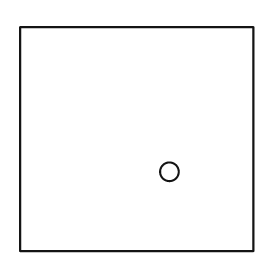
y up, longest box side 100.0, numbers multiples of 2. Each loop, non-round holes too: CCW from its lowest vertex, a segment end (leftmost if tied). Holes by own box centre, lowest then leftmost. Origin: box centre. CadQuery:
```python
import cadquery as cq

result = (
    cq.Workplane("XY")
    .moveTo(-50.0, -48.0)
    .lineTo(50.0, -48.0)
    .lineTo(50.0, 48.0)
    .lineTo(-50.0, 48.0)
    .close()
    .moveTo(14.0, -14.0)
    .circle(4.0)
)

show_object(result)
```